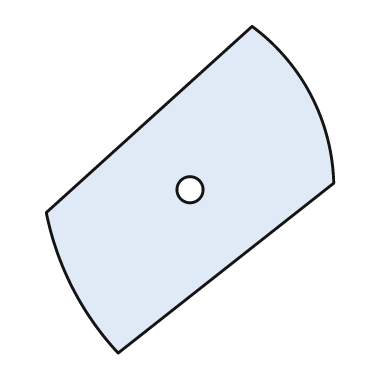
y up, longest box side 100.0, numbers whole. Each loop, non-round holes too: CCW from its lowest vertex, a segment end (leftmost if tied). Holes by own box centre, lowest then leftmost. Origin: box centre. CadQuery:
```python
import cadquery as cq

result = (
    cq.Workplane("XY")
    .moveTo(-22.0, -50.0)
    .lineTo(44.0, 2.0)
    .threePointArc((37.0, 29.0), (19.0, 50.0))
    .lineTo(-44.0, -7.0)
    .threePointArc((-36.0, -30.0), (-22.0, -50.0))
    .close()
    .moveTo(0.0, 0.0)
    .circle(4.0)
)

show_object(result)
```